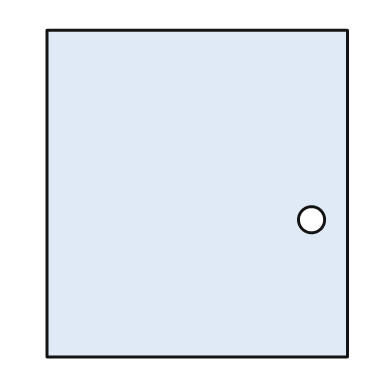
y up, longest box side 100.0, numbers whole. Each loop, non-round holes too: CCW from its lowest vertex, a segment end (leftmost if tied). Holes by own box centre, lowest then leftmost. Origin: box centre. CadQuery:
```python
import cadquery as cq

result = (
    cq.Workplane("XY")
    .moveTo(-46.0, -50.0)
    .lineTo(46.0, -50.0)
    .lineTo(46.0, 50.0)
    .lineTo(-46.0, 50.0)
    .close()
    .moveTo(35.0, -8.0)
    .circle(4.0)
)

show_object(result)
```